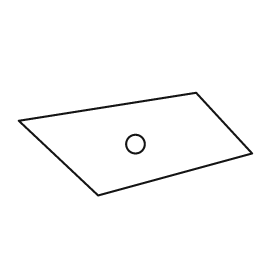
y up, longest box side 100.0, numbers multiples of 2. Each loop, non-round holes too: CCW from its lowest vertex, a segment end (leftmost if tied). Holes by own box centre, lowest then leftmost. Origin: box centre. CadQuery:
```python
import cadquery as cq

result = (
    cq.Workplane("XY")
    .moveTo(-16.0, -22.0)
    .lineTo(50.0, -4.0)
    .lineTo(26.0, 22.0)
    .lineTo(-50.0, 10.0)
    .close()
    .moveTo(0.0, 0.0)
    .circle(4.0)
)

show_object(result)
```